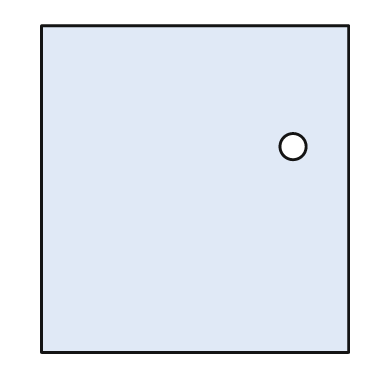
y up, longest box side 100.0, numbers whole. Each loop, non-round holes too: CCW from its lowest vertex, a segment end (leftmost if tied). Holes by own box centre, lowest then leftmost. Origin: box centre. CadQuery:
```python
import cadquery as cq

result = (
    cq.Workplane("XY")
    .moveTo(-47.0, -50.0)
    .lineTo(47.0, -50.0)
    .lineTo(47.0, 50.0)
    .lineTo(-47.0, 50.0)
    .close()
    .moveTo(30.0, 13.0)
    .circle(4.0)
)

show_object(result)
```